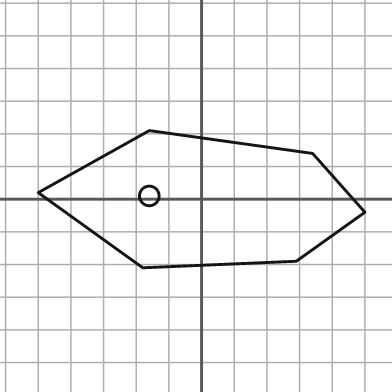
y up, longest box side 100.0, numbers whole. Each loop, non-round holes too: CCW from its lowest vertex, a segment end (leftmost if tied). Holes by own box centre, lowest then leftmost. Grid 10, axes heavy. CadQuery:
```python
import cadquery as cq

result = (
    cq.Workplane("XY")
    .moveTo(-18.0, -21.0)
    .lineTo(29.0, -19.0)
    .lineTo(50.0, -4.0)
    .lineTo(34.0, 14.0)
    .lineTo(-16.0, 21.0)
    .lineTo(-50.0, 2.0)
    .close()
    .moveTo(-16.0, 1.0)
    .circle(3.0)
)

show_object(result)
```